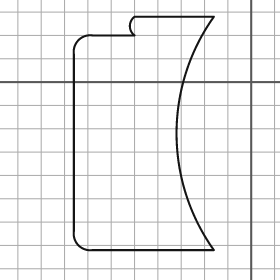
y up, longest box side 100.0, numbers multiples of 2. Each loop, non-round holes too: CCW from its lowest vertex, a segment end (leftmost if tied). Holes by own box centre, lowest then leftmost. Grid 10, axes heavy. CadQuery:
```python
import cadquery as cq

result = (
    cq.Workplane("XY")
    .moveTo(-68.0, -72.0)
    .lineTo(-16.0, -72.0)
    .threePointArc((-32.0, -22.0), (-16.0, 28.0))
    .lineTo(-50.0, 28.0)
    .threePointArc((-52.0, 24.0), (-50.0, 20.0))
    .lineTo(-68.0, 20.0)
    .threePointArc((-74.0, 18.0), (-76.0, 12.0))
    .lineTo(-76.0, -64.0)
    .threePointArc((-74.0, -70.0), (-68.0, -72.0))
    .close()
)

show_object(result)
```